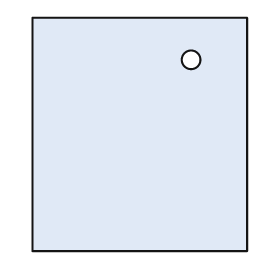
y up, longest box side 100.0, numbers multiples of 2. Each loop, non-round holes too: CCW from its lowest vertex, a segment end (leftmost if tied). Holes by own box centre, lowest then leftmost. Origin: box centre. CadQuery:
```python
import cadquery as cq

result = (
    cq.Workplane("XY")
    .moveTo(-46.0, -50.0)
    .lineTo(46.0, -50.0)
    .lineTo(46.0, 50.0)
    .lineTo(-46.0, 50.0)
    .close()
    .moveTo(22.0, 32.0)
    .circle(4.0)
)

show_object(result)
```